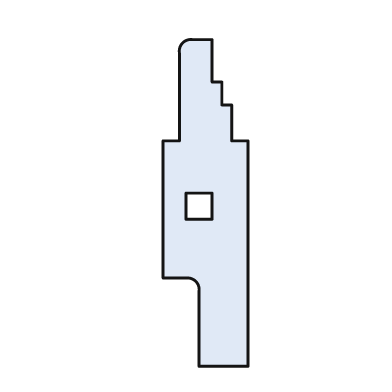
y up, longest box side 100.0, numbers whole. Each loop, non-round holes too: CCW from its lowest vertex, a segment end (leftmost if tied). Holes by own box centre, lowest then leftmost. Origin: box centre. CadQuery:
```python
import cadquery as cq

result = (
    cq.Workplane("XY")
    .moveTo(-2.0, -50.0)
    .lineTo(13.0, -50.0)
    .lineTo(13.0, 19.0)
    .lineTo(8.0, 19.0)
    .lineTo(8.0, 30.0)
    .lineTo(5.0, 30.0)
    .lineTo(5.0, 37.0)
    .lineTo(2.0, 37.0)
    .lineTo(2.0, 50.0)
    .lineTo(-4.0, 50.0)
    .threePointArc((-7.0, 49.0), (-8.0, 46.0))
    .lineTo(-8.0, 19.0)
    .lineTo(-13.0, 19.0)
    .lineTo(-13.0, -23.0)
    .lineTo(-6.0, -23.0)
    .threePointArc((-3.0, -24.0), (-2.0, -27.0))
    .close()
    .moveTo(-6.0, -5.0)
    .lineTo(2.0, -5.0)
    .lineTo(2.0, 3.0)
    .lineTo(-6.0, 3.0)
    .close()
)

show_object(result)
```